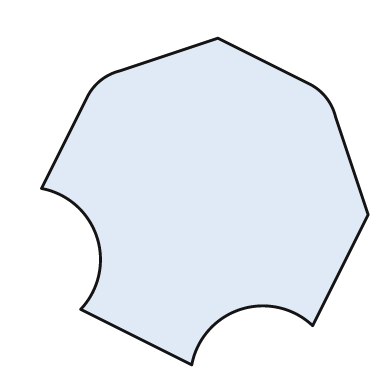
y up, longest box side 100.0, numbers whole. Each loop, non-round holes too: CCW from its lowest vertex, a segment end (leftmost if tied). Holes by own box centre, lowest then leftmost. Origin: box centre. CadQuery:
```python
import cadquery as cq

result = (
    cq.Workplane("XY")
    .moveTo(-4.0, -50.0)
    .threePointArc((11.0, -33.0), (33.0, -38.0))
    .lineTo(50.0, -4.0)
    .lineTo(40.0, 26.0)
    .threePointArc((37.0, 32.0), (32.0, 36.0))
    .lineTo(4.0, 50.0)
    .lineTo(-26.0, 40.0)
    .threePointArc((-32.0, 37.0), (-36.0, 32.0))
    .lineTo(-50.0, 4.0)
    .threePointArc((-33.0, -11.0), (-38.0, -33.0))
    .close()
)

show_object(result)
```